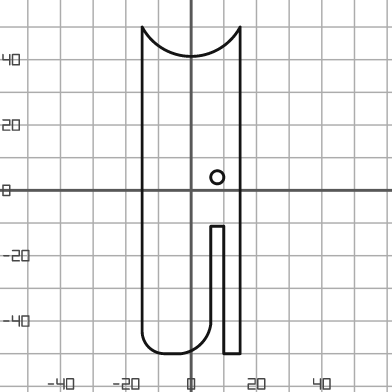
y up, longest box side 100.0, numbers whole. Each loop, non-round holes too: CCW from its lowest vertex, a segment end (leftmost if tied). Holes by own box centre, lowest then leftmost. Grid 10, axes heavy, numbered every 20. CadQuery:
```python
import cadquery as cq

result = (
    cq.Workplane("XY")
    .moveTo(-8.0, -50.0)
    .lineTo(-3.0, -50.0)
    .threePointArc((3.0, -47.0), (6.0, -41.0))
    .lineTo(6.0, -11.0)
    .lineTo(10.0, -11.0)
    .lineTo(10.0, -50.0)
    .lineTo(15.0, -50.0)
    .lineTo(15.0, 50.0)
    .threePointArc((0.0, 41.0), (-15.0, 50.0))
    .lineTo(-15.0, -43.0)
    .threePointArc((-13.0, -48.0), (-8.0, -50.0))
    .close()
    .moveTo(8.0, 4.0)
    .circle(2.0)
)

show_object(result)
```